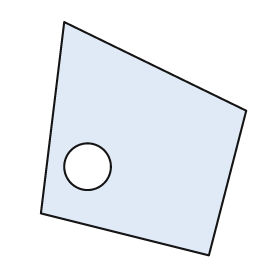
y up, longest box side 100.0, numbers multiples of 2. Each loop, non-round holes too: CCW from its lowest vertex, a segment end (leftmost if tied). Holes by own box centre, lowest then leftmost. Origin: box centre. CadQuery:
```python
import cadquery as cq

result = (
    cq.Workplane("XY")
    .moveTo(28.0, -50.0)
    .lineTo(44.0, 12.0)
    .lineTo(-34.0, 50.0)
    .lineTo(-44.0, -32.0)
    .close()
    .moveTo(-24.0, -12.0)
    .circle(10.0)
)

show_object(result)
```